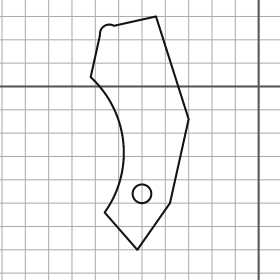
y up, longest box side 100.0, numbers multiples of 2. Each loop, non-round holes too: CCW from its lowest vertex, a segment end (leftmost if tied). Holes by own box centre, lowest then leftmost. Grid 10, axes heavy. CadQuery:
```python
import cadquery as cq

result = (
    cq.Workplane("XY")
    .moveTo(-52.0, -70.0)
    .lineTo(-38.0, -50.0)
    .lineTo(-30.0, -14.0)
    .lineTo(-44.0, 30.0)
    .lineTo(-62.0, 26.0)
    .threePointArc((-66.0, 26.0), (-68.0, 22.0))
    .lineTo(-72.0, 4.0)
    .threePointArc((-58.0, -24.0), (-66.0, -54.0))
    .close()
    .moveTo(-50.0, -46.0)
    .circle(4.0)
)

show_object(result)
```